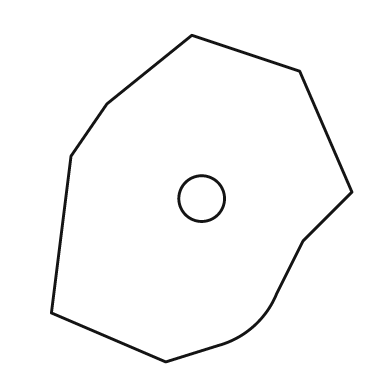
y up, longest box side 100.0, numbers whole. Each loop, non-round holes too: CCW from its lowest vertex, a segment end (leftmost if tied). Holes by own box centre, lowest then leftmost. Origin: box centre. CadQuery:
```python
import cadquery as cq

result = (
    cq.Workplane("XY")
    .moveTo(-11.0, -50.0)
    .lineTo(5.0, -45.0)
    .threePointArc((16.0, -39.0), (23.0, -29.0))
    .lineTo(31.0, -13.0)
    .lineTo(46.0, 2.0)
    .lineTo(30.0, 39.0)
    .lineTo(-3.0, 50.0)
    .lineTo(-29.0, 29.0)
    .lineTo(-40.0, 13.0)
    .lineTo(-46.0, -35.0)
    .close()
    .moveTo(0.0, 0.0)
    .circle(7.0)
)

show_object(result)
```